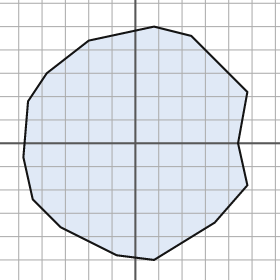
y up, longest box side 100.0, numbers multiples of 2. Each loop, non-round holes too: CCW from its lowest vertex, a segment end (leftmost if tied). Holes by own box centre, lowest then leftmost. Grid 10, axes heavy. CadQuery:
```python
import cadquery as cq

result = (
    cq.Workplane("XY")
    .moveTo(8.0, -50.0)
    .lineTo(34.0, -34.0)
    .lineTo(48.0, -18.0)
    .lineTo(44.0, 0.0)
    .lineTo(48.0, 22.0)
    .lineTo(24.0, 46.0)
    .lineTo(8.0, 50.0)
    .lineTo(-20.0, 44.0)
    .lineTo(-38.0, 30.0)
    .lineTo(-46.0, 18.0)
    .lineTo(-48.0, -6.0)
    .lineTo(-44.0, -24.0)
    .lineTo(-32.0, -36.0)
    .lineTo(-8.0, -48.0)
    .close()
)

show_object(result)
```